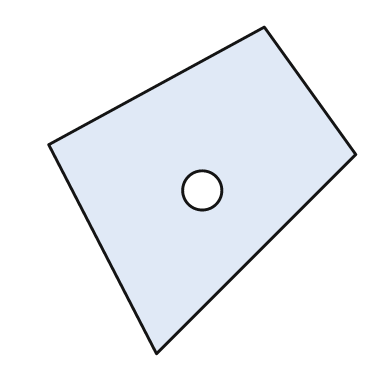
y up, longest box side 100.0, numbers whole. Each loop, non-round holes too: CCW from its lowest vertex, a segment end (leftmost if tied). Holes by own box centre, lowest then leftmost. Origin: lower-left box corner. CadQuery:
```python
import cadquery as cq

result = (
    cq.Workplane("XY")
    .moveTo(33.0, 0.0)
    .lineTo(94.0, 61.0)
    .lineTo(66.0, 100.0)
    .lineTo(0.0, 64.0)
    .close()
    .moveTo(47.0, 50.0)
    .circle(6.0)
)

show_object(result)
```